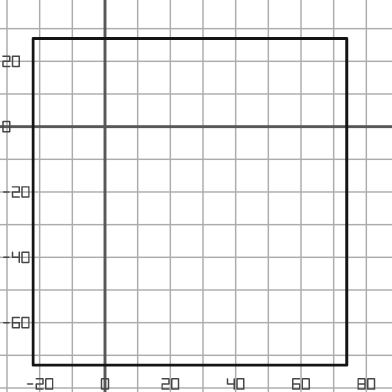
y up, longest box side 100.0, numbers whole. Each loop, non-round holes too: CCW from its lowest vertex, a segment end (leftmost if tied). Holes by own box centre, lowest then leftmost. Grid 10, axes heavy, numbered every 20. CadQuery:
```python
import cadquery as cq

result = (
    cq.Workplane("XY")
    .moveTo(-22.0, -73.0)
    .lineTo(74.0, -73.0)
    .lineTo(74.0, 27.0)
    .lineTo(-22.0, 27.0)
    .close()
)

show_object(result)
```